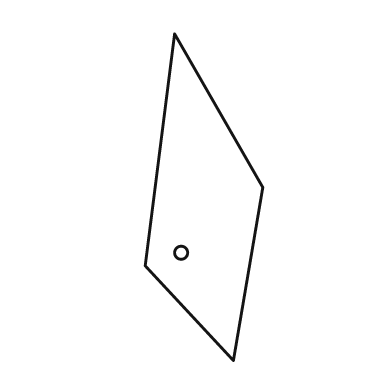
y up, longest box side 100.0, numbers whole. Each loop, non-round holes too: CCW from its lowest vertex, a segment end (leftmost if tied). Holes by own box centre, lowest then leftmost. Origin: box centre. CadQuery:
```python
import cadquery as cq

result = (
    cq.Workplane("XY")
    .moveTo(9.0, -50.0)
    .lineTo(18.0, 3.0)
    .lineTo(-9.0, 50.0)
    .lineTo(-18.0, -21.0)
    .close()
    .moveTo(-7.0, -17.0)
    .circle(2.0)
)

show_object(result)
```